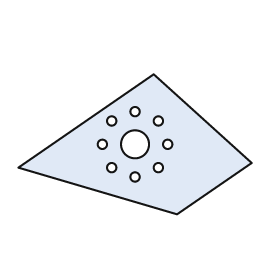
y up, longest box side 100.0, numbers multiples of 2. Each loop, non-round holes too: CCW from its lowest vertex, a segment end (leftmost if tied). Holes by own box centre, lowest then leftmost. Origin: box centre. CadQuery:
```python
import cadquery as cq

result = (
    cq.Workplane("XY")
    .moveTo(18.0, -30.0)
    .lineTo(50.0, -8.0)
    .lineTo(8.0, 30.0)
    .lineTo(-50.0, -10.0)
    .close()
    .moveTo(0.0, -14.0)
    .circle(2.0)
    .moveTo(-10.0, -10.0)
    .circle(2.0)
    .moveTo(10.0, -10.0)
    .circle(2.0)
    .moveTo(-14.0, 0.0)
    .circle(2.0)
    .moveTo(0.0, 0.0)
    .circle(6.0)
    .moveTo(14.0, 0.0)
    .circle(2.0)
    .moveTo(-10.0, 10.0)
    .circle(2.0)
    .moveTo(10.0, 10.0)
    .circle(2.0)
    .moveTo(0.0, 14.0)
    .circle(2.0)
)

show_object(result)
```